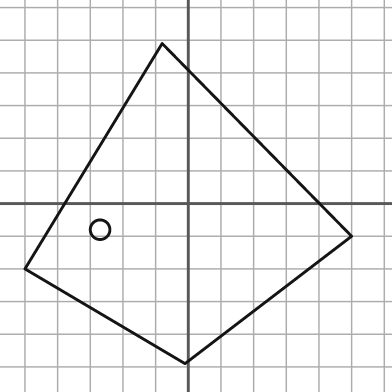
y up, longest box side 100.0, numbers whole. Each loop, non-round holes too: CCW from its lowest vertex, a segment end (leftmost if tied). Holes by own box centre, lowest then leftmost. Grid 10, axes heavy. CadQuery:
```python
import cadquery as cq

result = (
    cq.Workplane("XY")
    .moveTo(-1.0, -49.0)
    .lineTo(50.0, -10.0)
    .lineTo(-8.0, 49.0)
    .lineTo(-50.0, -20.0)
    .close()
    .moveTo(-27.0, -8.0)
    .circle(3.0)
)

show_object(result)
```